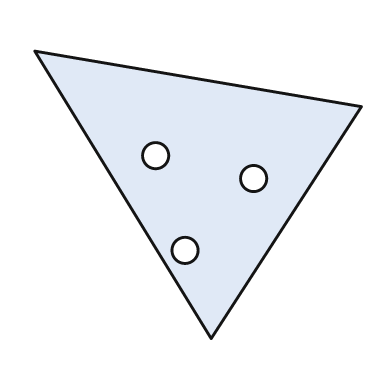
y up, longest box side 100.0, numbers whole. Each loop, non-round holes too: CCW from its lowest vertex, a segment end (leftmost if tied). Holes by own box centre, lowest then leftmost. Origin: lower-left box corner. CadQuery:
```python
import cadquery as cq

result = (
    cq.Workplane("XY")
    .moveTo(54.0, 0.0)
    .lineTo(100.0, 71.0)
    .lineTo(0.0, 88.0)
    .close()
    .moveTo(46.0, 27.0)
    .circle(4.0)
    .moveTo(67.0, 49.0)
    .circle(4.0)
    .moveTo(37.0, 56.0)
    .circle(4.0)
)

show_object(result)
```